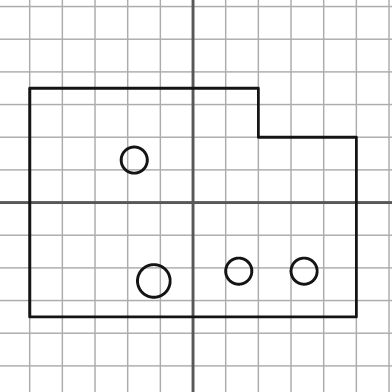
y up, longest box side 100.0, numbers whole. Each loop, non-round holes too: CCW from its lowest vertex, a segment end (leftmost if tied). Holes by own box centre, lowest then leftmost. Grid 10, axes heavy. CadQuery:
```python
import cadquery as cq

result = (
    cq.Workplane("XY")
    .moveTo(-50.0, -35.0)
    .lineTo(50.0, -35.0)
    .lineTo(50.0, 20.0)
    .lineTo(20.0, 20.0)
    .lineTo(20.0, 35.0)
    .lineTo(-50.0, 35.0)
    .close()
    .moveTo(-12.0, -24.0)
    .circle(5.0)
    .moveTo(14.0, -21.0)
    .circle(4.0)
    .moveTo(34.0, -21.0)
    .circle(4.0)
    .moveTo(-18.0, 13.0)
    .circle(4.0)
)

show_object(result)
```